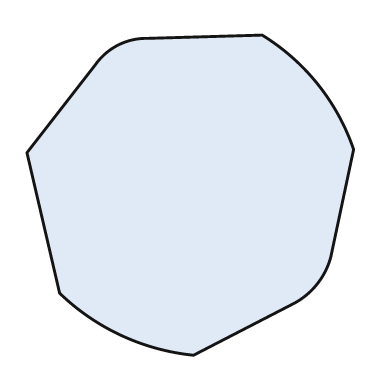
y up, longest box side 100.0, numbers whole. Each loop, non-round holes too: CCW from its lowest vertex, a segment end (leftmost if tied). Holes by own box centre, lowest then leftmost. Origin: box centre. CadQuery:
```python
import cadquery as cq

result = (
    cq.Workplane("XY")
    .moveTo(1.0, -49.0)
    .lineTo(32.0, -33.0)
    .threePointArc((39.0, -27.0), (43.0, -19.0))
    .lineTo(50.0, 14.0)
    .threePointArc((39.0, 34.0), (22.0, 49.0))
    .lineTo(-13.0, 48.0)
    .threePointArc((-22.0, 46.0), (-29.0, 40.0))
    .lineTo(-50.0, 13.0)
    .lineTo(-40.0, -30.0)
    .threePointArc((-21.0, -43.0), (1.0, -49.0))
    .close()
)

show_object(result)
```